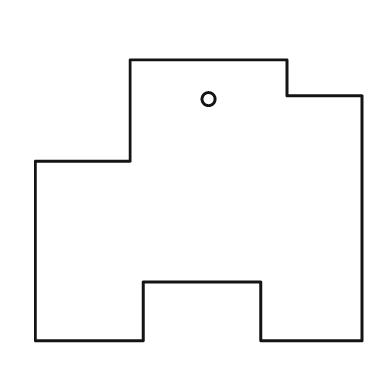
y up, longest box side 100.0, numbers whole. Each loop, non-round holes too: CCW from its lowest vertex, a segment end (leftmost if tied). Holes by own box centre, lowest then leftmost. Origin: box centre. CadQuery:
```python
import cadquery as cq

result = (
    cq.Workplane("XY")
    .moveTo(-50.0, -43.0)
    .lineTo(-17.0, -43.0)
    .lineTo(-17.0, -25.0)
    .lineTo(19.0, -25.0)
    .lineTo(19.0, -43.0)
    .lineTo(50.0, -43.0)
    .lineTo(50.0, 32.0)
    .lineTo(27.0, 32.0)
    .lineTo(27.0, 43.0)
    .lineTo(-21.0, 43.0)
    .lineTo(-21.0, 12.0)
    .lineTo(-50.0, 12.0)
    .close()
    .moveTo(3.0, 31.0)
    .circle(2.0)
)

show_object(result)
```